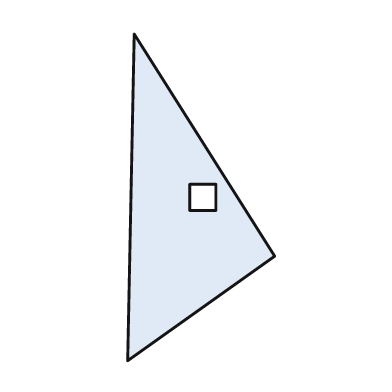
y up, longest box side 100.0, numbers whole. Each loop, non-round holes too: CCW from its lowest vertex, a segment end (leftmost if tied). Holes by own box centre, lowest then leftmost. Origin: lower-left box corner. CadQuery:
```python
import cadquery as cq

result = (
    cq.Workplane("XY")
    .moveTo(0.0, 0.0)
    .lineTo(45.0, 32.0)
    .lineTo(2.0, 100.0)
    .close()
    .moveTo(19.0, 46.0)
    .lineTo(27.0, 46.0)
    .lineTo(27.0, 54.0)
    .lineTo(19.0, 54.0)
    .close()
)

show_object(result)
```